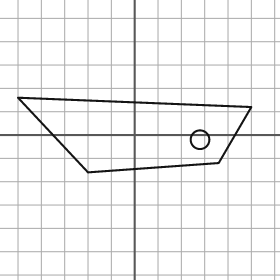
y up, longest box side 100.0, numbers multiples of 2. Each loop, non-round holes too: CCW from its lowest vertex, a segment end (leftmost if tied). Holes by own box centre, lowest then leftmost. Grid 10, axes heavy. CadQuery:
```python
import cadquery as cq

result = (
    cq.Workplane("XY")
    .moveTo(-20.0, -16.0)
    .lineTo(36.0, -12.0)
    .lineTo(50.0, 12.0)
    .lineTo(-50.0, 16.0)
    .close()
    .moveTo(28.0, -2.0)
    .circle(4.0)
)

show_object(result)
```